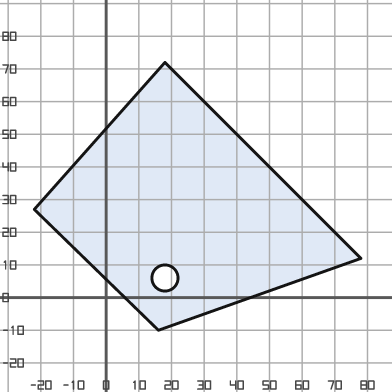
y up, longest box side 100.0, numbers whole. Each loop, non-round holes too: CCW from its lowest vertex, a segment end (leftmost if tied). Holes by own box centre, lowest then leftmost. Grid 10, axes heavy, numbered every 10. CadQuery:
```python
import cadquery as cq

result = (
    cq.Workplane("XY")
    .moveTo(16.0, -10.0)
    .lineTo(78.0, 12.0)
    .lineTo(18.0, 72.0)
    .lineTo(-22.0, 27.0)
    .close()
    .moveTo(18.0, 6.0)
    .circle(4.0)
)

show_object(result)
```